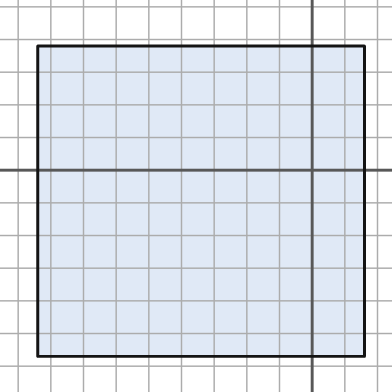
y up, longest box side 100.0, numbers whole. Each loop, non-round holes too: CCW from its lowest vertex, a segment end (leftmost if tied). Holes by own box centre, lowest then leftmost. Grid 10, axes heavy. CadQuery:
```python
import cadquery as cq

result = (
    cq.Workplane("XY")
    .moveTo(-84.0, -57.0)
    .lineTo(16.0, -57.0)
    .lineTo(16.0, 38.0)
    .lineTo(-84.0, 38.0)
    .close()
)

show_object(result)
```